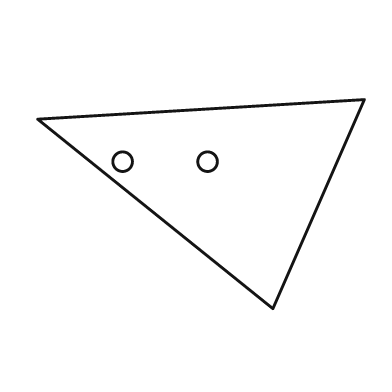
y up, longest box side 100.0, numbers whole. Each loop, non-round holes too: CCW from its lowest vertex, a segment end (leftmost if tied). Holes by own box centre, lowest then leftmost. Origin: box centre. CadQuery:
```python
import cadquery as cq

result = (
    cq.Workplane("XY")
    .moveTo(22.0, -32.0)
    .lineTo(50.0, 32.0)
    .lineTo(-50.0, 26.0)
    .close()
    .moveTo(-24.0, 13.0)
    .circle(3.0)
    .moveTo(2.0, 13.0)
    .circle(3.0)
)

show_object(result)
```